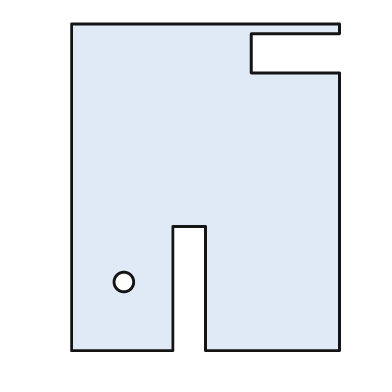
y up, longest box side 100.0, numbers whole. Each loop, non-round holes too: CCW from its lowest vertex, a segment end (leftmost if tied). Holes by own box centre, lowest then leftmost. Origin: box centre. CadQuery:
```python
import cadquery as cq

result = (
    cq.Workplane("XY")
    .moveTo(-41.0, -50.0)
    .lineTo(-10.0, -50.0)
    .lineTo(-10.0, -12.0)
    .lineTo(0.0, -12.0)
    .lineTo(0.0, -50.0)
    .lineTo(41.0, -50.0)
    .lineTo(41.0, 35.0)
    .lineTo(14.0, 35.0)
    .lineTo(14.0, 47.0)
    .lineTo(41.0, 47.0)
    .lineTo(41.0, 50.0)
    .lineTo(-41.0, 50.0)
    .close()
    .moveTo(-25.0, -29.0)
    .circle(3.0)
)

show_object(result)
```